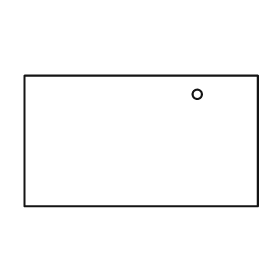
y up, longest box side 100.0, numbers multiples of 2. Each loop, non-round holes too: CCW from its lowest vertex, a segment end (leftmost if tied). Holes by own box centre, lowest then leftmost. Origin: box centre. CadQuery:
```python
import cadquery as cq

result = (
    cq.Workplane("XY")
    .moveTo(-50.0, -28.0)
    .lineTo(50.0, -28.0)
    .lineTo(50.0, 28.0)
    .lineTo(-50.0, 28.0)
    .close()
    .moveTo(24.0, 20.0)
    .circle(2.0)
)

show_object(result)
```